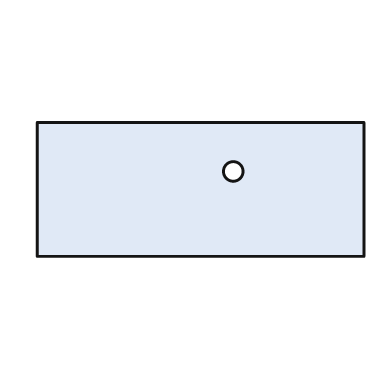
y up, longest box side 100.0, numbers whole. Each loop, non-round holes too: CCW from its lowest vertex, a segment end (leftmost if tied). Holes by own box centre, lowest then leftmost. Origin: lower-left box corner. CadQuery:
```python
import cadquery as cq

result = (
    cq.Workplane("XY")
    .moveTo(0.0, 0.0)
    .lineTo(100.0, 0.0)
    .lineTo(100.0, 41.0)
    .lineTo(0.0, 41.0)
    .close()
    .moveTo(60.0, 26.0)
    .circle(3.0)
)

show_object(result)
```